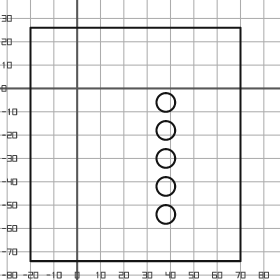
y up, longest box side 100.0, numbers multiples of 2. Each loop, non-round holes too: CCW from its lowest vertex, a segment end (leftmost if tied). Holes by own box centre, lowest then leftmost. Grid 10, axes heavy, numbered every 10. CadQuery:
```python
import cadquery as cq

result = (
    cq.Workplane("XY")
    .moveTo(-20.0, -74.0)
    .lineTo(70.0, -74.0)
    .lineTo(70.0, 26.0)
    .lineTo(-20.0, 26.0)
    .close()
    .moveTo(38.0, -54.0)
    .circle(4.0)
    .moveTo(38.0, -42.0)
    .circle(4.0)
    .moveTo(38.0, -30.0)
    .circle(4.0)
    .moveTo(38.0, -18.0)
    .circle(4.0)
    .moveTo(38.0, -6.0)
    .circle(4.0)
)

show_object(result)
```